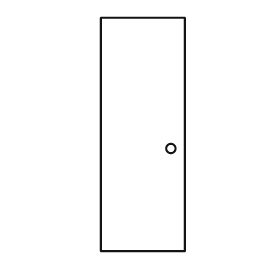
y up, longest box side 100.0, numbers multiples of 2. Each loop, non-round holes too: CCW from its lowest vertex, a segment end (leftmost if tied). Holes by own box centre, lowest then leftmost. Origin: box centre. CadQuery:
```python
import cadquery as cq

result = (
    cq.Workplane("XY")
    .moveTo(-18.0, -50.0)
    .lineTo(18.0, -50.0)
    .lineTo(18.0, 50.0)
    .lineTo(-18.0, 50.0)
    .close()
    .moveTo(12.0, -6.0)
    .circle(2.0)
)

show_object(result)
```